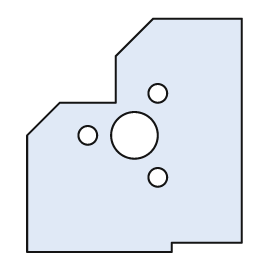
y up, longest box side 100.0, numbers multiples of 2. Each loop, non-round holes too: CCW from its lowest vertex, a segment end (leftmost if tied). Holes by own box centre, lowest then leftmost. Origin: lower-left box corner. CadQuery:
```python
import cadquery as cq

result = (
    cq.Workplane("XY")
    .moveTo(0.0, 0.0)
    .lineTo(62.0, 0.0)
    .lineTo(62.0, 4.0)
    .lineTo(92.0, 4.0)
    .lineTo(92.0, 100.0)
    .lineTo(54.0, 100.0)
    .lineTo(38.0, 84.0)
    .lineTo(38.0, 64.0)
    .lineTo(14.0, 64.0)
    .lineTo(0.0, 50.0)
    .close()
    .moveTo(56.0, 32.0)
    .circle(4.0)
    .moveTo(26.0, 50.0)
    .circle(4.0)
    .moveTo(46.0, 50.0)
    .circle(10.0)
    .moveTo(56.0, 68.0)
    .circle(4.0)
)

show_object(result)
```